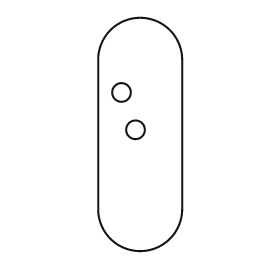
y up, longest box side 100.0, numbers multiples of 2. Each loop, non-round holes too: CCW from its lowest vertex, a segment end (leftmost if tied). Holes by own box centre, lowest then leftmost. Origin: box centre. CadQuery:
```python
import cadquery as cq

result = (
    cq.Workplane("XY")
    .moveTo(-18.0, -32.0)
    .threePointArc((0.0, -50.0), (18.0, -32.0))
    .lineTo(18.0, 32.0)
    .threePointArc((0.0, 50.0), (-18.0, 32.0))
    .close()
    .moveTo(-2.0, 2.0)
    .circle(4.0)
    .moveTo(-8.0, 18.0)
    .circle(4.0)
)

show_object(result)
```